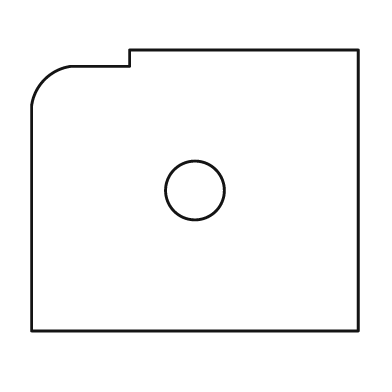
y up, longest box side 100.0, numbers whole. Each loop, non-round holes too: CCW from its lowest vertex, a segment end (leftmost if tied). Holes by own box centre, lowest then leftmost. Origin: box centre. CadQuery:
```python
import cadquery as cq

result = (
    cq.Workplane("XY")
    .moveTo(-50.0, -43.0)
    .lineTo(50.0, -43.0)
    .lineTo(50.0, 43.0)
    .lineTo(-20.0, 43.0)
    .lineTo(-20.0, 38.0)
    .lineTo(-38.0, 38.0)
    .threePointArc((-46.0, 34.0), (-50.0, 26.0))
    .close()
    .moveTo(0.0, 0.0)
    .circle(9.0)
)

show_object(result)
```